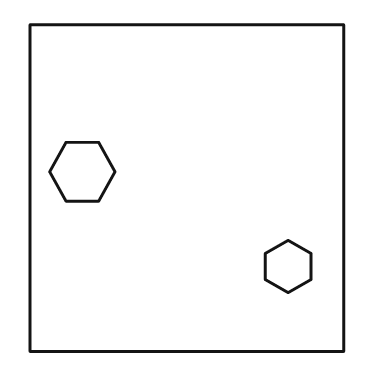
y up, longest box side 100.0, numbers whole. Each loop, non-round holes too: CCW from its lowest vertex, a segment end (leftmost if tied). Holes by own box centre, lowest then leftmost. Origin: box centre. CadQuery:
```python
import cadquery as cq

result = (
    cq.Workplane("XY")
    .moveTo(-48.0, -50.0)
    .lineTo(48.0, -50.0)
    .lineTo(48.0, 50.0)
    .lineTo(-48.0, 50.0)
    .close()
    .moveTo(31.0, -32.0)
    .lineTo(38.0, -28.0)
    .lineTo(38.0, -20.0)
    .lineTo(31.0, -16.0)
    .lineTo(24.0, -20.0)
    .lineTo(24.0, -28.0)
    .close()
    .moveTo(-37.0, -4.0)
    .lineTo(-27.0, -4.0)
    .lineTo(-22.0, 5.0)
    .lineTo(-27.0, 14.0)
    .lineTo(-37.0, 14.0)
    .lineTo(-42.0, 5.0)
    .close()
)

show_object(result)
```